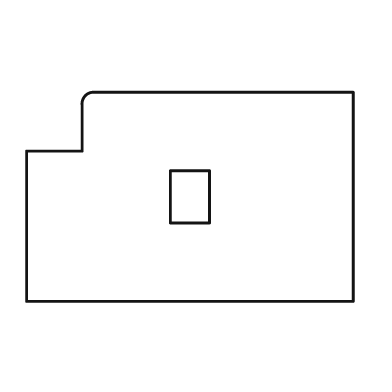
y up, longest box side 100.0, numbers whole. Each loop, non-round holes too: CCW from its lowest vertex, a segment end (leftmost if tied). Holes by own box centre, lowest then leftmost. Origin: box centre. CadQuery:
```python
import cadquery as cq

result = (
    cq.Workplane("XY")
    .moveTo(-50.0, -32.0)
    .lineTo(50.0, -32.0)
    .lineTo(50.0, 32.0)
    .lineTo(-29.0, 32.0)
    .threePointArc((-32.0, 31.0), (-33.0, 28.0))
    .lineTo(-33.0, 14.0)
    .lineTo(-50.0, 14.0)
    .close()
    .moveTo(-6.0, -8.0)
    .lineTo(6.0, -8.0)
    .lineTo(6.0, 8.0)
    .lineTo(-6.0, 8.0)
    .close()
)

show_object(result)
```